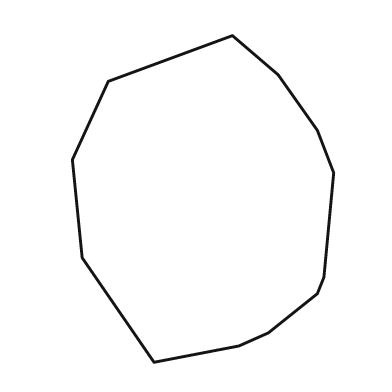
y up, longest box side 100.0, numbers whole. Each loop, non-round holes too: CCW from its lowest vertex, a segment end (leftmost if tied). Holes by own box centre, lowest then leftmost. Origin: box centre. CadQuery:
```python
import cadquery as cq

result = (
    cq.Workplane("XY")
    .moveTo(-15.0, -50.0)
    .lineTo(11.0, -45.0)
    .lineTo(20.0, -41.0)
    .lineTo(35.0, -29.0)
    .lineTo(37.0, -24.0)
    .lineTo(40.0, 8.0)
    .lineTo(35.0, 21.0)
    .lineTo(23.0, 38.0)
    .lineTo(9.0, 50.0)
    .lineTo(-29.0, 36.0)
    .lineTo(-40.0, 12.0)
    .lineTo(-37.0, -18.0)
    .close()
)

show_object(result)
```